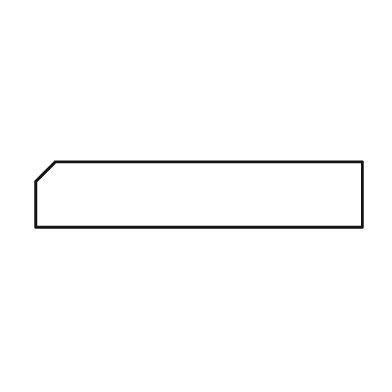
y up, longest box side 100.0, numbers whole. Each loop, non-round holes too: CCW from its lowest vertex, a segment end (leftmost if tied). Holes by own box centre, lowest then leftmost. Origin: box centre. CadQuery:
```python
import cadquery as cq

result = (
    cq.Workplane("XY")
    .moveTo(-50.0, -10.0)
    .lineTo(50.0, -10.0)
    .lineTo(50.0, 10.0)
    .lineTo(-44.0, 10.0)
    .lineTo(-50.0, 4.0)
    .close()
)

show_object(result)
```